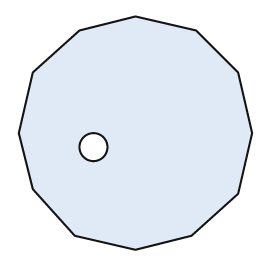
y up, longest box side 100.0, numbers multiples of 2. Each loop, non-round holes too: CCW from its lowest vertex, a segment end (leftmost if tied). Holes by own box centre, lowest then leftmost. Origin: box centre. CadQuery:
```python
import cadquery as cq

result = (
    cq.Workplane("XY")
    .moveTo(0.0, -50.0)
    .lineTo(24.0, -44.0)
    .lineTo(44.0, -26.0)
    .lineTo(50.0, 0.0)
    .lineTo(44.0, 26.0)
    .lineTo(26.0, 44.0)
    .lineTo(0.0, 50.0)
    .lineTo(-24.0, 44.0)
    .lineTo(-44.0, 26.0)
    .lineTo(-50.0, 0.0)
    .lineTo(-44.0, -24.0)
    .lineTo(-26.0, -44.0)
    .close()
    .moveTo(-18.0, -6.0)
    .circle(6.0)
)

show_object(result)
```